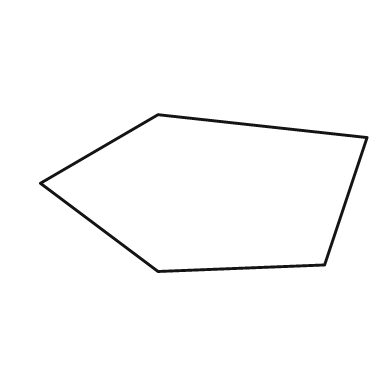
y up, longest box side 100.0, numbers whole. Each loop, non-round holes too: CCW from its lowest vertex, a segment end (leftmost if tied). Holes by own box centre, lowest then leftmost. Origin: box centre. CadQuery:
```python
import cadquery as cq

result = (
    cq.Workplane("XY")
    .moveTo(-14.0, -24.0)
    .lineTo(37.0, -22.0)
    .lineTo(50.0, 17.0)
    .lineTo(-14.0, 24.0)
    .lineTo(-50.0, 3.0)
    .close()
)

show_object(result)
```